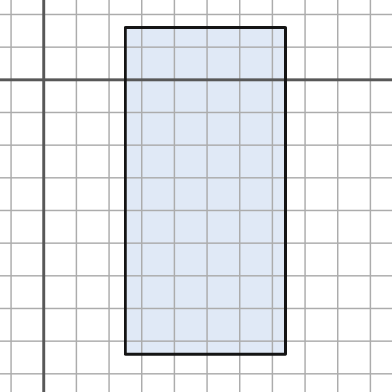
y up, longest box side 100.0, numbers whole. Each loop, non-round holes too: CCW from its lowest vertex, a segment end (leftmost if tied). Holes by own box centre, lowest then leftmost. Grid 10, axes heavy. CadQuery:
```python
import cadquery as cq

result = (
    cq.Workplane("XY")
    .moveTo(25.0, -84.0)
    .lineTo(74.0, -84.0)
    .lineTo(74.0, 16.0)
    .lineTo(25.0, 16.0)
    .close()
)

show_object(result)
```